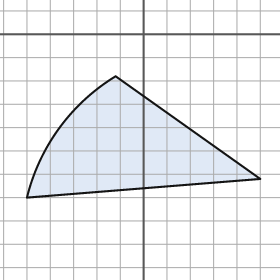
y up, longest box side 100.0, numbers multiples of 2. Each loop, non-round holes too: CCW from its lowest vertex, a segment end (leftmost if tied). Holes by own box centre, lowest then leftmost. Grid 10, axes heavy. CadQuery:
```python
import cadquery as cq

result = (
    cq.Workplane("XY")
    .moveTo(-50.0, -70.0)
    .lineTo(50.0, -62.0)
    .lineTo(-12.0, -18.0)
    .threePointArc((-36.0, -40.0), (-50.0, -70.0))
    .close()
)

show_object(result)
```